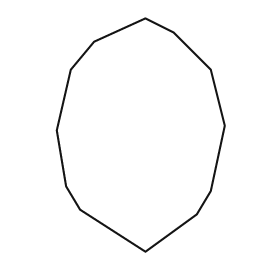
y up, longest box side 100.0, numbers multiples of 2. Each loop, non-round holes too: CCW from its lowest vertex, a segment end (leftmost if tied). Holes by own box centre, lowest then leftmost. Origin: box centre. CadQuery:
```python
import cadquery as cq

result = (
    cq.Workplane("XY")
    .moveTo(2.0, -50.0)
    .lineTo(24.0, -34.0)
    .lineTo(30.0, -24.0)
    .lineTo(36.0, 4.0)
    .lineTo(30.0, 28.0)
    .lineTo(14.0, 44.0)
    .lineTo(2.0, 50.0)
    .lineTo(-20.0, 40.0)
    .lineTo(-30.0, 28.0)
    .lineTo(-36.0, 2.0)
    .lineTo(-32.0, -22.0)
    .lineTo(-26.0, -32.0)
    .close()
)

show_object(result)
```